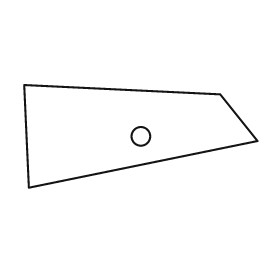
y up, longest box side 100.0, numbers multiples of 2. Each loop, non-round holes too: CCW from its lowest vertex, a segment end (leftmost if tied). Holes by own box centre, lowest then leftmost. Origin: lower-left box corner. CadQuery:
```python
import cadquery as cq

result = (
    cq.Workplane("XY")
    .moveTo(2.0, 0.0)
    .lineTo(100.0, 20.0)
    .lineTo(84.0, 40.0)
    .lineTo(0.0, 44.0)
    .close()
    .moveTo(50.0, 22.0)
    .circle(4.0)
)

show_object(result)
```